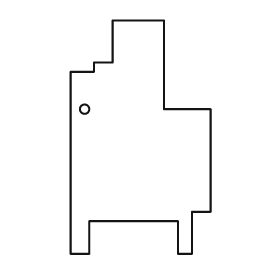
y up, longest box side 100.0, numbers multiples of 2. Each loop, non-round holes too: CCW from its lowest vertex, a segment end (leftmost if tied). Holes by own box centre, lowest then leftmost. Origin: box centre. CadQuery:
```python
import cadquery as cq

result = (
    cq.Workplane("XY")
    .moveTo(-30.0, -50.0)
    .lineTo(-22.0, -50.0)
    .lineTo(-22.0, -36.0)
    .lineTo(16.0, -36.0)
    .lineTo(16.0, -50.0)
    .lineTo(22.0, -50.0)
    .lineTo(22.0, -32.0)
    .lineTo(30.0, -32.0)
    .lineTo(30.0, 12.0)
    .lineTo(10.0, 12.0)
    .lineTo(10.0, 50.0)
    .lineTo(-12.0, 50.0)
    .lineTo(-12.0, 32.0)
    .lineTo(-20.0, 32.0)
    .lineTo(-20.0, 28.0)
    .lineTo(-30.0, 28.0)
    .close()
    .moveTo(-24.0, 12.0)
    .circle(2.0)
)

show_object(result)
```